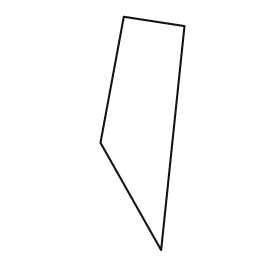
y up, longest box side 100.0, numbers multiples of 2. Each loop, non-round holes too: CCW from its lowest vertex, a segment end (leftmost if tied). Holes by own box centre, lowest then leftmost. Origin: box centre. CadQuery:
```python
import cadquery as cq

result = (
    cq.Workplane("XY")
    .moveTo(8.0, -50.0)
    .lineTo(18.0, 46.0)
    .lineTo(-8.0, 50.0)
    .lineTo(-18.0, -4.0)
    .close()
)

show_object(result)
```